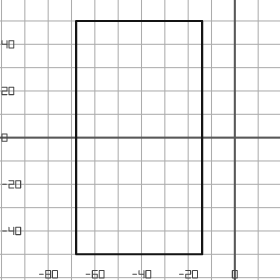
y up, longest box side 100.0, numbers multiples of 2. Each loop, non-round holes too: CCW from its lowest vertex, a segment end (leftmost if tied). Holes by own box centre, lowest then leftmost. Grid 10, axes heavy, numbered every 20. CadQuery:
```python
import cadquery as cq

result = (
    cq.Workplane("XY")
    .moveTo(-68.0, -50.0)
    .lineTo(-14.0, -50.0)
    .lineTo(-14.0, 50.0)
    .lineTo(-68.0, 50.0)
    .close()
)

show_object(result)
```